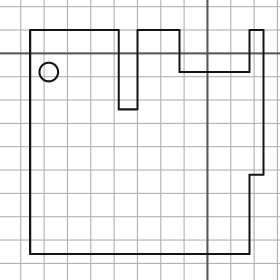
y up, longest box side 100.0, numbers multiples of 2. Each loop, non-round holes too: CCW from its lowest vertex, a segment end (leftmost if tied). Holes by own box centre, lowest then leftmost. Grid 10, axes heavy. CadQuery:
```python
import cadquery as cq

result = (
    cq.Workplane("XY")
    .moveTo(-76.0, -86.0)
    .lineTo(18.0, -86.0)
    .lineTo(18.0, -52.0)
    .lineTo(24.0, -52.0)
    .lineTo(24.0, 10.0)
    .lineTo(18.0, 10.0)
    .lineTo(18.0, -8.0)
    .lineTo(-12.0, -8.0)
    .lineTo(-12.0, 10.0)
    .lineTo(-30.0, 10.0)
    .lineTo(-30.0, -24.0)
    .lineTo(-38.0, -24.0)
    .lineTo(-38.0, 10.0)
    .lineTo(-76.0, 10.0)
    .close()
    .moveTo(-68.0, -8.0)
    .circle(4.0)
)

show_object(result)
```